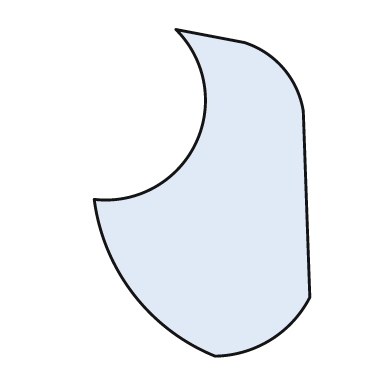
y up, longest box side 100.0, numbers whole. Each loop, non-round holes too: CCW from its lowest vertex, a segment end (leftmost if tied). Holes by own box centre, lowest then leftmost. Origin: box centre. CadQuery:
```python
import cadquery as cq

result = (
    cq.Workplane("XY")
    .moveTo(4.0, -50.0)
    .threePointArc((21.0, -45.0), (33.0, -32.0))
    .lineTo(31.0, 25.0)
    .threePointArc((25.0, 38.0), (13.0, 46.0))
    .lineTo(-8.0, 50.0)
    .threePointArc((-2.0, 15.0), (-33.0, -2.0))
    .threePointArc((-21.0, -31.0), (4.0, -50.0))
    .close()
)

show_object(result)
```